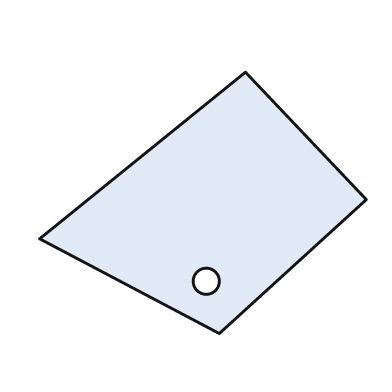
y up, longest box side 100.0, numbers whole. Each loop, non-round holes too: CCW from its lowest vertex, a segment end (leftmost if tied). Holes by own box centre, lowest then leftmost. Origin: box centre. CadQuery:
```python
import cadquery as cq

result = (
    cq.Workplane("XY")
    .moveTo(5.0, -40.0)
    .lineTo(50.0, 1.0)
    .lineTo(13.0, 40.0)
    .lineTo(-50.0, -11.0)
    .close()
    .moveTo(1.0, -24.0)
    .circle(4.0)
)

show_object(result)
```